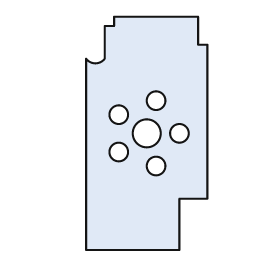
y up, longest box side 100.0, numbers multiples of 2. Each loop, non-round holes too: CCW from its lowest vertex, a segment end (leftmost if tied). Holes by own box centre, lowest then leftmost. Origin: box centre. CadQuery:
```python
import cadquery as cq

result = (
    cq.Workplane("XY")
    .moveTo(-26.0, -50.0)
    .lineTo(14.0, -50.0)
    .lineTo(14.0, -28.0)
    .lineTo(26.0, -28.0)
    .lineTo(26.0, 38.0)
    .lineTo(22.0, 38.0)
    .lineTo(22.0, 50.0)
    .lineTo(-14.0, 50.0)
    .lineTo(-14.0, 46.0)
    .lineTo(-18.0, 46.0)
    .lineTo(-18.0, 32.0)
    .threePointArc((-22.0, 30.0), (-26.0, 32.0))
    .close()
    .moveTo(4.0, -14.0)
    .circle(4.0)
    .moveTo(-12.0, -8.0)
    .circle(4.0)
    .moveTo(0.0, 0.0)
    .circle(6.0)
    .moveTo(14.0, 0.0)
    .circle(4.0)
    .moveTo(-12.0, 8.0)
    .circle(4.0)
    .moveTo(4.0, 14.0)
    .circle(4.0)
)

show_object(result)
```